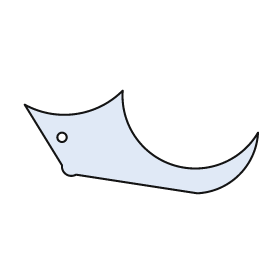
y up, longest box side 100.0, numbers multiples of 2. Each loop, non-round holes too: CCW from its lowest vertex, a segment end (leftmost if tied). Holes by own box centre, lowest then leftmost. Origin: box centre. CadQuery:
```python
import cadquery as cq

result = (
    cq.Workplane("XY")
    .moveTo(24.0, -22.0)
    .threePointArc((42.0, -14.0), (50.0, 4.0))
    .threePointArc((14.0, -10.0), (-8.0, 22.0))
    .threePointArc((-28.0, 12.0), (-50.0, 16.0))
    .lineTo(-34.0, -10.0)
    .threePointArc((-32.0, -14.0), (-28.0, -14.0))
    .close()
    .moveTo(-34.0, 2.0)
    .circle(2.0)
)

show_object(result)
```